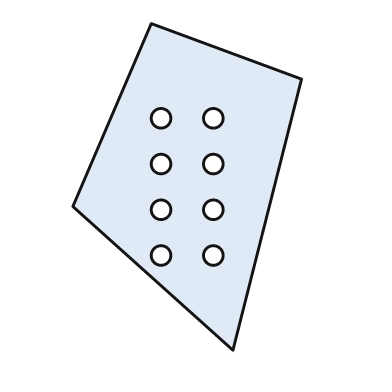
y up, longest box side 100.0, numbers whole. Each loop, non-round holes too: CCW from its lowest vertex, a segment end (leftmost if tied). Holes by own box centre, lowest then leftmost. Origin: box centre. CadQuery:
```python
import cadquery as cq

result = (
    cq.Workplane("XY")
    .moveTo(14.0, -50.0)
    .lineTo(35.0, 33.0)
    .lineTo(-11.0, 50.0)
    .lineTo(-35.0, -6.0)
    .close()
    .moveTo(-8.0, -21.0)
    .circle(3.0)
    .moveTo(8.0, -21.0)
    .circle(3.0)
    .moveTo(-8.0, -7.0)
    .circle(3.0)
    .moveTo(8.0, -7.0)
    .circle(3.0)
    .moveTo(-8.0, 7.0)
    .circle(3.0)
    .moveTo(8.0, 7.0)
    .circle(3.0)
    .moveTo(-8.0, 21.0)
    .circle(3.0)
    .moveTo(8.0, 21.0)
    .circle(3.0)
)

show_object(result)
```